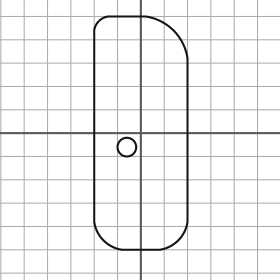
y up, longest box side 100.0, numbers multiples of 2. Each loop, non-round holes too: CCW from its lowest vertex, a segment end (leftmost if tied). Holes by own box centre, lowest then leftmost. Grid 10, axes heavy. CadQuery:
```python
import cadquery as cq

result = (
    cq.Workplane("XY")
    .moveTo(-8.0, -50.0)
    .lineTo(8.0, -50.0)
    .threePointArc((16.0, -46.0), (20.0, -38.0))
    .lineTo(20.0, 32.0)
    .threePointArc((14.0, 44.0), (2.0, 50.0))
    .lineTo(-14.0, 50.0)
    .threePointArc((-18.0, 48.0), (-20.0, 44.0))
    .lineTo(-20.0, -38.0)
    .threePointArc((-16.0, -46.0), (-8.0, -50.0))
    .close()
    .moveTo(-6.0, -6.0)
    .circle(4.0)
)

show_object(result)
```